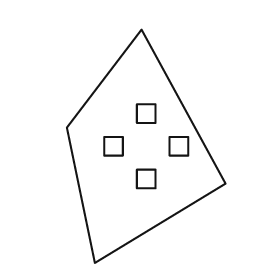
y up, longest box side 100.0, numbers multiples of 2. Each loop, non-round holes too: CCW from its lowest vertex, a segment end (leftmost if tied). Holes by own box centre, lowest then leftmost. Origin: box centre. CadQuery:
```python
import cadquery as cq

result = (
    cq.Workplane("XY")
    .moveTo(-22.0, -50.0)
    .lineTo(34.0, -16.0)
    .lineTo(-2.0, 50.0)
    .lineTo(-34.0, 8.0)
    .close()
    .moveTo(-4.0, -18.0)
    .lineTo(4.0, -18.0)
    .lineTo(4.0, -10.0)
    .lineTo(-4.0, -10.0)
    .close()
    .moveTo(-18.0, -4.0)
    .lineTo(-10.0, -4.0)
    .lineTo(-10.0, 4.0)
    .lineTo(-18.0, 4.0)
    .close()
    .moveTo(10.0, -4.0)
    .lineTo(18.0, -4.0)
    .lineTo(18.0, 4.0)
    .lineTo(10.0, 4.0)
    .close()
    .moveTo(-4.0, 10.0)
    .lineTo(4.0, 10.0)
    .lineTo(4.0, 18.0)
    .lineTo(-4.0, 18.0)
    .close()
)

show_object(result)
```